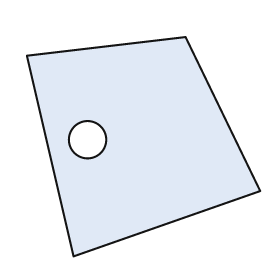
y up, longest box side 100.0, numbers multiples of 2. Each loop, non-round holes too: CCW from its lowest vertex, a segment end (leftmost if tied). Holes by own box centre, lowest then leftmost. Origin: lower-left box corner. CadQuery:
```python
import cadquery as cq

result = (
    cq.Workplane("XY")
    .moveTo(20.0, 0.0)
    .lineTo(100.0, 28.0)
    .lineTo(68.0, 94.0)
    .lineTo(0.0, 86.0)
    .close()
    .moveTo(26.0, 50.0)
    .circle(8.0)
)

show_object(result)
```